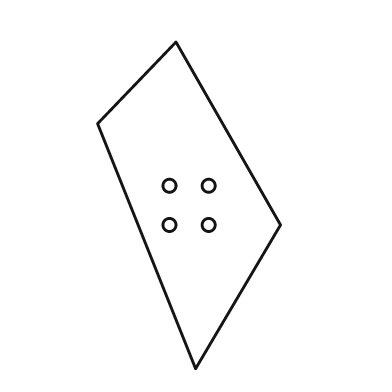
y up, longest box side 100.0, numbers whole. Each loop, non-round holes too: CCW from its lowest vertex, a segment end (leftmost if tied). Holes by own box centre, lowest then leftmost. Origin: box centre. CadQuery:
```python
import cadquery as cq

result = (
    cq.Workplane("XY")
    .moveTo(2.0, -50.0)
    .lineTo(28.0, -6.0)
    .lineTo(-4.0, 50.0)
    .lineTo(-28.0, 25.0)
    .close()
    .moveTo(-6.0, -6.0)
    .circle(2.0)
    .moveTo(6.0, -6.0)
    .circle(2.0)
    .moveTo(-6.0, 6.0)
    .circle(2.0)
    .moveTo(6.0, 6.0)
    .circle(2.0)
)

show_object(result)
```